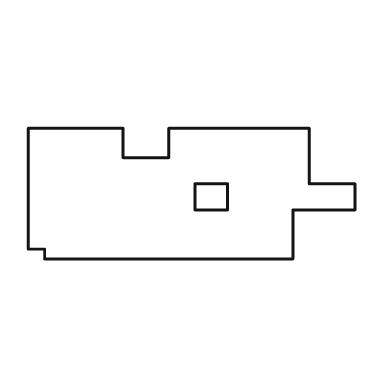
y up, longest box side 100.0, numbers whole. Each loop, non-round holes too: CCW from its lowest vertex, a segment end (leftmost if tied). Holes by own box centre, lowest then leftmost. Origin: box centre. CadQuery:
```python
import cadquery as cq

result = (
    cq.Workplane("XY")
    .moveTo(-45.0, -20.0)
    .lineTo(31.0, -20.0)
    .lineTo(31.0, -5.0)
    .lineTo(50.0, -5.0)
    .lineTo(50.0, 3.0)
    .lineTo(36.0, 3.0)
    .lineTo(36.0, 20.0)
    .lineTo(-7.0, 20.0)
    .lineTo(-7.0, 11.0)
    .lineTo(-21.0, 11.0)
    .lineTo(-21.0, 20.0)
    .lineTo(-50.0, 20.0)
    .lineTo(-50.0, -17.0)
    .lineTo(-45.0, -17.0)
    .close()
    .moveTo(1.0, -5.0)
    .lineTo(11.0, -5.0)
    .lineTo(11.0, 3.0)
    .lineTo(1.0, 3.0)
    .close()
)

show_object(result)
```